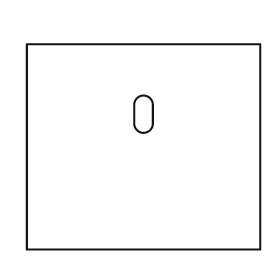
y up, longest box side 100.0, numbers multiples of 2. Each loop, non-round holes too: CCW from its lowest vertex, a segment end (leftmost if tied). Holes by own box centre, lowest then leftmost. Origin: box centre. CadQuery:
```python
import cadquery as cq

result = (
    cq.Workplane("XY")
    .moveTo(-50.0, -44.0)
    .lineTo(50.0, -44.0)
    .lineTo(50.0, 44.0)
    .lineTo(-50.0, 44.0)
    .close()
    .moveTo(-4.0, 10.0)
    .threePointArc((0.0, 6.0), (4.0, 10.0))
    .lineTo(4.0, 18.0)
    .threePointArc((0.0, 22.0), (-4.0, 18.0))
    .close()
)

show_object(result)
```